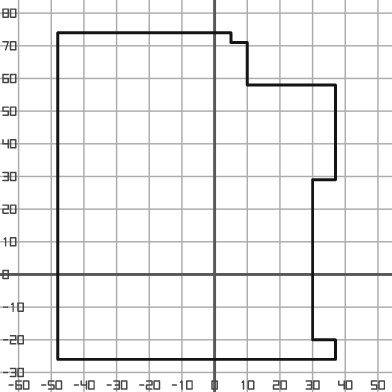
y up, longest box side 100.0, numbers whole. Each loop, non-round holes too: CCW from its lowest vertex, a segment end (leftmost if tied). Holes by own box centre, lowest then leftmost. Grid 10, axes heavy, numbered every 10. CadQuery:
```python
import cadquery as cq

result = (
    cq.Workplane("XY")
    .moveTo(-48.0, -26.0)
    .lineTo(37.0, -26.0)
    .lineTo(37.0, -20.0)
    .lineTo(30.0, -20.0)
    .lineTo(30.0, 29.0)
    .lineTo(37.0, 29.0)
    .lineTo(37.0, 58.0)
    .lineTo(10.0, 58.0)
    .lineTo(10.0, 71.0)
    .lineTo(5.0, 71.0)
    .lineTo(5.0, 74.0)
    .lineTo(-48.0, 74.0)
    .close()
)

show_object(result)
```